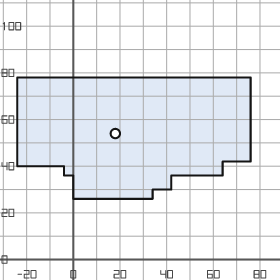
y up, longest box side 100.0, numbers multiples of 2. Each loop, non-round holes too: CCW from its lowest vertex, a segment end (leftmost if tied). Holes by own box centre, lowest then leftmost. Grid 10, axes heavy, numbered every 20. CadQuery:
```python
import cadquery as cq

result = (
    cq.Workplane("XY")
    .moveTo(0.0, 26.0)
    .lineTo(34.0, 26.0)
    .lineTo(34.0, 30.0)
    .lineTo(42.0, 30.0)
    .lineTo(42.0, 36.0)
    .lineTo(64.0, 36.0)
    .lineTo(64.0, 42.0)
    .lineTo(76.0, 42.0)
    .lineTo(76.0, 78.0)
    .lineTo(-24.0, 78.0)
    .lineTo(-24.0, 40.0)
    .lineTo(-4.0, 40.0)
    .lineTo(-4.0, 36.0)
    .lineTo(0.0, 36.0)
    .close()
    .moveTo(18.0, 54.0)
    .circle(2.0)
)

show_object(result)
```